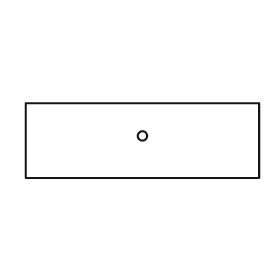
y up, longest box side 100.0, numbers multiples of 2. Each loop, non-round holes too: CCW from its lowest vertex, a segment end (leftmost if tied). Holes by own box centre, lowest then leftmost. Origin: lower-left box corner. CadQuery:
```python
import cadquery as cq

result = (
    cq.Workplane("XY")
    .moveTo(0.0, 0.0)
    .lineTo(100.0, 0.0)
    .lineTo(100.0, 32.0)
    .lineTo(0.0, 32.0)
    .close()
    .moveTo(50.0, 18.0)
    .circle(2.0)
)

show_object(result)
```